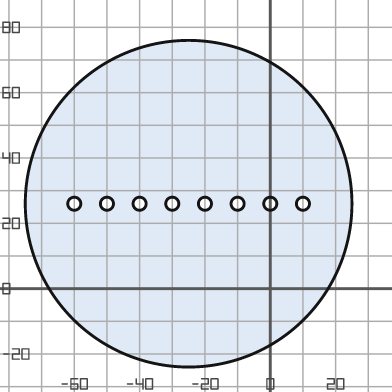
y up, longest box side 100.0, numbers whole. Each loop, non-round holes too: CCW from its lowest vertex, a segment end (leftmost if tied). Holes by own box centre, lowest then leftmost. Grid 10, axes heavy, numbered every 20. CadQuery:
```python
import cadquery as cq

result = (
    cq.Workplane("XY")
    .moveTo(-25.0, 26.0)
    .circle(50.0)
    .moveTo(-60.0, 26.0)
    .circle(2.0)
    .moveTo(-50.0, 26.0)
    .circle(2.0)
    .moveTo(-40.0, 26.0)
    .circle(2.0)
    .moveTo(-30.0, 26.0)
    .circle(2.0)
    .moveTo(-20.0, 26.0)
    .circle(2.0)
    .moveTo(-10.0, 26.0)
    .circle(2.0)
    .moveTo(0.0, 26.0)
    .circle(2.0)
    .moveTo(10.0, 26.0)
    .circle(2.0)
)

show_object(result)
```